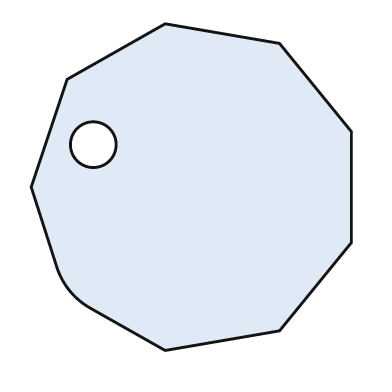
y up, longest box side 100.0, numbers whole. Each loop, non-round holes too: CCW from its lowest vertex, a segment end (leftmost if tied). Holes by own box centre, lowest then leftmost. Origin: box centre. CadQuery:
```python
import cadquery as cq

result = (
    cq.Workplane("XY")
    .moveTo(-8.0, -50.0)
    .lineTo(27.0, -44.0)
    .lineTo(49.0, -17.0)
    .lineTo(49.0, 17.0)
    .lineTo(27.0, 44.0)
    .lineTo(-8.0, 50.0)
    .lineTo(-38.0, 33.0)
    .lineTo(-49.0, 0.0)
    .lineTo(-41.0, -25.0)
    .threePointArc((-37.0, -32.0), (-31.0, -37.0))
    .close()
    .moveTo(-30.0, 13.0)
    .circle(7.0)
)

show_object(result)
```